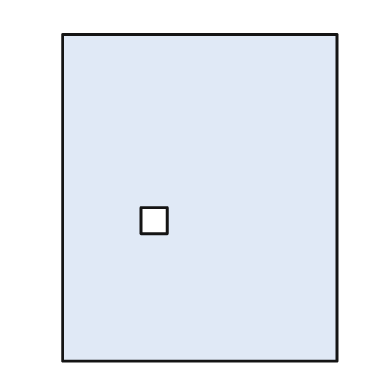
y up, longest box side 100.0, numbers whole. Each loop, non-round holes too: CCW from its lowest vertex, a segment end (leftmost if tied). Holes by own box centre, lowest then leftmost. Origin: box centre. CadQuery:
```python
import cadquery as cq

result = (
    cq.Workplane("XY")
    .moveTo(-42.0, -50.0)
    .lineTo(42.0, -50.0)
    .lineTo(42.0, 50.0)
    .lineTo(-42.0, 50.0)
    .close()
    .moveTo(-18.0, -11.0)
    .lineTo(-10.0, -11.0)
    .lineTo(-10.0, -3.0)
    .lineTo(-18.0, -3.0)
    .close()
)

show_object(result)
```